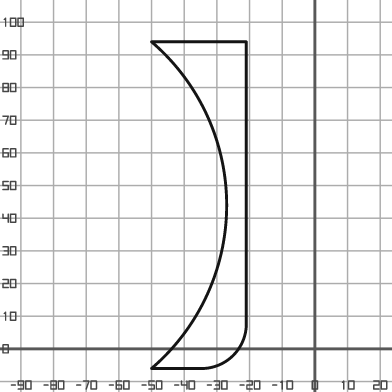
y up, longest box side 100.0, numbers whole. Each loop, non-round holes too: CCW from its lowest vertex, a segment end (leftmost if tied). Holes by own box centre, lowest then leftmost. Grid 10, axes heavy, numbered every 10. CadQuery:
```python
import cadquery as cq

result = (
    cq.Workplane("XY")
    .moveTo(-50.0, -6.0)
    .lineTo(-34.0, -6.0)
    .threePointArc((-25.0, -2.0), (-21.0, 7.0))
    .lineTo(-21.0, 94.0)
    .lineTo(-50.0, 94.0)
    .threePointArc((-27.0, 44.0), (-50.0, -6.0))
    .close()
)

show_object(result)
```